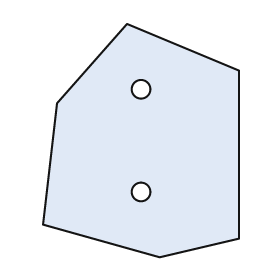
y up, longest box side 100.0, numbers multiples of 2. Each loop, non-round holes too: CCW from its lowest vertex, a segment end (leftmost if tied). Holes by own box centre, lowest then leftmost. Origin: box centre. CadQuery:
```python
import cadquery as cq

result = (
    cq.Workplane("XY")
    .moveTo(8.0, -50.0)
    .lineTo(42.0, -42.0)
    .lineTo(42.0, 30.0)
    .lineTo(-6.0, 50.0)
    .lineTo(-36.0, 16.0)
    .lineTo(-42.0, -36.0)
    .close()
    .moveTo(0.0, -22.0)
    .circle(4.0)
    .moveTo(0.0, 22.0)
    .circle(4.0)
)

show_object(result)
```